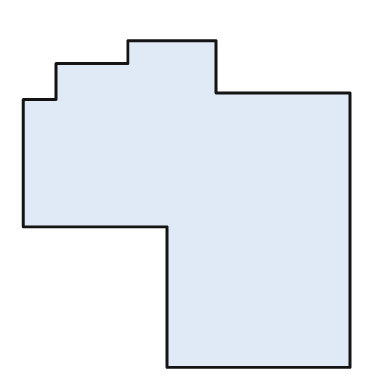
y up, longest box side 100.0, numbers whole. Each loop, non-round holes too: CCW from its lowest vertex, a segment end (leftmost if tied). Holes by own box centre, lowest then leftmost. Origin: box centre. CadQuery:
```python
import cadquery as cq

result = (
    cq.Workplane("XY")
    .moveTo(-6.0, -50.0)
    .lineTo(50.0, -50.0)
    .lineTo(50.0, 34.0)
    .lineTo(9.0, 34.0)
    .lineTo(9.0, 50.0)
    .lineTo(-18.0, 50.0)
    .lineTo(-18.0, 43.0)
    .lineTo(-40.0, 43.0)
    .lineTo(-40.0, 32.0)
    .lineTo(-50.0, 32.0)
    .lineTo(-50.0, -7.0)
    .lineTo(-6.0, -7.0)
    .close()
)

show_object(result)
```